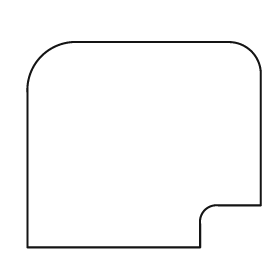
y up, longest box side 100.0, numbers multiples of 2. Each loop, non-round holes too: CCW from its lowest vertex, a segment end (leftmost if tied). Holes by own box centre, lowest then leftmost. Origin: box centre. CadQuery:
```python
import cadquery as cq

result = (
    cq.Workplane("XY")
    .moveTo(-50.0, -44.0)
    .lineTo(24.0, -44.0)
    .lineTo(24.0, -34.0)
    .threePointArc((26.0, -28.0), (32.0, -26.0))
    .lineTo(50.0, -26.0)
    .lineTo(50.0, 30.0)
    .threePointArc((46.0, 40.0), (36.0, 44.0))
    .lineTo(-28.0, 44.0)
    .threePointArc((-44.0, 38.0), (-50.0, 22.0))
    .close()
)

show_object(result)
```